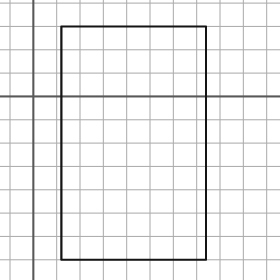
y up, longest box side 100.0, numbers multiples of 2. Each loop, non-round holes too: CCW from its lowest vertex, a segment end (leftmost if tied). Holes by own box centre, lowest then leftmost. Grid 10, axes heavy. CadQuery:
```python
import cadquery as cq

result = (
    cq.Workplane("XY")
    .moveTo(12.0, -70.0)
    .lineTo(74.0, -70.0)
    .lineTo(74.0, 30.0)
    .lineTo(12.0, 30.0)
    .close()
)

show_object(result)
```